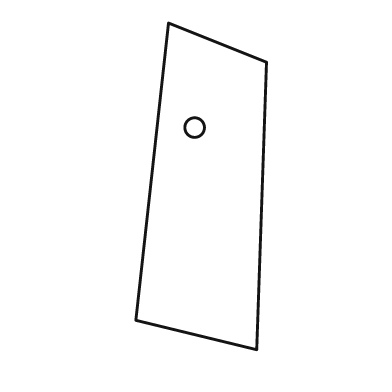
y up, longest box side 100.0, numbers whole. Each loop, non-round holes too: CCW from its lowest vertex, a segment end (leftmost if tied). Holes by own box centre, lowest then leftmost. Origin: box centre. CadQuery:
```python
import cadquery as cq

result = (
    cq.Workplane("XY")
    .moveTo(17.0, -50.0)
    .lineTo(20.0, 38.0)
    .lineTo(-10.0, 50.0)
    .lineTo(-20.0, -41.0)
    .close()
    .moveTo(-2.0, 18.0)
    .circle(3.0)
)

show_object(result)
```